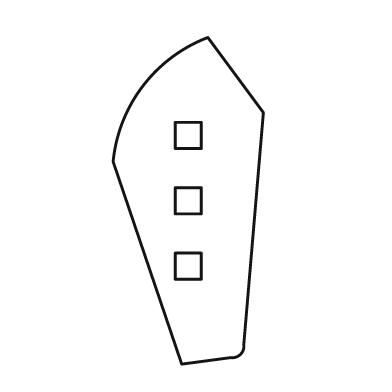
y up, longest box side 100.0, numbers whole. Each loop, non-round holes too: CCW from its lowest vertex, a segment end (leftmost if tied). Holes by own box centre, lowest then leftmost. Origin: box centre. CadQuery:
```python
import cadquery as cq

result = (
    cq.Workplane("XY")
    .moveTo(-2.0, -50.0)
    .lineTo(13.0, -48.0)
    .threePointArc((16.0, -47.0), (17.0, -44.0))
    .lineTo(23.0, 27.0)
    .lineTo(6.0, 50.0)
    .threePointArc((-14.0, 35.0), (-23.0, 12.0))
    .close()
    .moveTo(-4.0, -24.0)
    .lineTo(4.0, -24.0)
    .lineTo(4.0, -16.0)
    .lineTo(-4.0, -16.0)
    .close()
    .moveTo(-4.0, -4.0)
    .lineTo(4.0, -4.0)
    .lineTo(4.0, 4.0)
    .lineTo(-4.0, 4.0)
    .close()
    .moveTo(-4.0, 16.0)
    .lineTo(4.0, 16.0)
    .lineTo(4.0, 24.0)
    .lineTo(-4.0, 24.0)
    .close()
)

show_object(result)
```